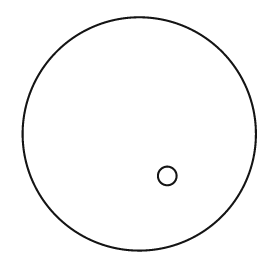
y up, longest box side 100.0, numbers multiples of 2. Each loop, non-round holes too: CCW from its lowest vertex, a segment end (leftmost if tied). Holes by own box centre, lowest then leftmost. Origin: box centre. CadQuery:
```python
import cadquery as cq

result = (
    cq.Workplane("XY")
    .moveTo(0.0, 0.0)
    .circle(50.0)
    .moveTo(12.0, -18.0)
    .circle(4.0)
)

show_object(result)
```